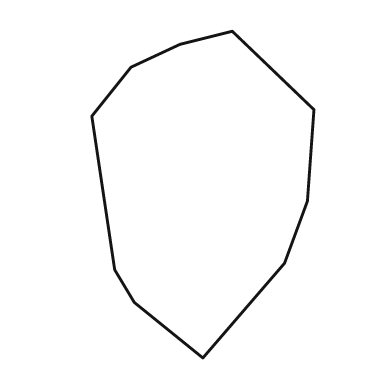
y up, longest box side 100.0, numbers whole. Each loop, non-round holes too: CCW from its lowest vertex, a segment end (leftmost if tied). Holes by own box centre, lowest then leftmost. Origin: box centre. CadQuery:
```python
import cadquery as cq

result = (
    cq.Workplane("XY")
    .moveTo(0.0, -50.0)
    .lineTo(25.0, -21.0)
    .lineTo(32.0, -2.0)
    .lineTo(34.0, 26.0)
    .lineTo(9.0, 50.0)
    .lineTo(-7.0, 46.0)
    .lineTo(-22.0, 39.0)
    .lineTo(-34.0, 24.0)
    .lineTo(-27.0, -23.0)
    .lineTo(-21.0, -33.0)
    .close()
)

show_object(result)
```